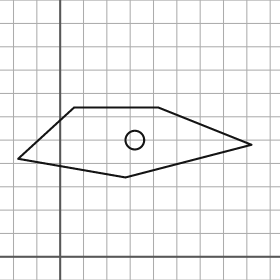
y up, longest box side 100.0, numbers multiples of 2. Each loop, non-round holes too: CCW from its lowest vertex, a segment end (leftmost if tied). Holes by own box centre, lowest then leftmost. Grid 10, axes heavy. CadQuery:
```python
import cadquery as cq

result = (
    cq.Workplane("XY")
    .moveTo(28.0, 34.0)
    .lineTo(82.0, 48.0)
    .lineTo(42.0, 64.0)
    .lineTo(6.0, 64.0)
    .lineTo(-18.0, 42.0)
    .close()
    .moveTo(32.0, 50.0)
    .circle(4.0)
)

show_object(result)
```